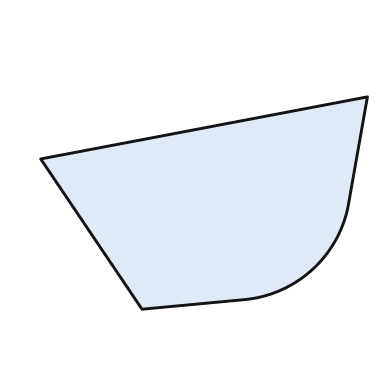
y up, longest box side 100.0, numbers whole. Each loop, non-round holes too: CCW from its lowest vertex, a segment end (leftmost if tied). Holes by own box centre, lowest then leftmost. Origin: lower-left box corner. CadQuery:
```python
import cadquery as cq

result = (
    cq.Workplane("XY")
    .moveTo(31.0, 0.0)
    .lineTo(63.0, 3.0)
    .threePointArc((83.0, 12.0), (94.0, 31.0))
    .lineTo(100.0, 65.0)
    .lineTo(0.0, 46.0)
    .close()
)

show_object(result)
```